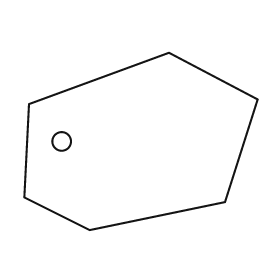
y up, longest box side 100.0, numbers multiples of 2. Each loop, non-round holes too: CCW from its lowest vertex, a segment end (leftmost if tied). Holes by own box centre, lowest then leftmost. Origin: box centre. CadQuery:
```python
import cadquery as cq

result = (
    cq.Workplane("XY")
    .moveTo(-22.0, -38.0)
    .lineTo(36.0, -26.0)
    .lineTo(50.0, 18.0)
    .lineTo(12.0, 38.0)
    .lineTo(-48.0, 16.0)
    .lineTo(-50.0, -24.0)
    .close()
    .moveTo(-34.0, 0.0)
    .circle(4.0)
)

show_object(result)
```